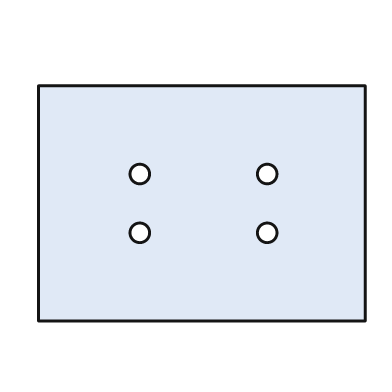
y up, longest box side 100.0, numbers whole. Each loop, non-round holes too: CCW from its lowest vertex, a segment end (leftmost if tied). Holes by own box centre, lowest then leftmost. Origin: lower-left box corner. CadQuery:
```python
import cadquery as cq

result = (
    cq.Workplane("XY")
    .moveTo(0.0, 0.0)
    .lineTo(100.0, 0.0)
    .lineTo(100.0, 72.0)
    .lineTo(0.0, 72.0)
    .close()
    .moveTo(31.0, 27.0)
    .circle(3.0)
    .moveTo(70.0, 27.0)
    .circle(3.0)
    .moveTo(31.0, 45.0)
    .circle(3.0)
    .moveTo(70.0, 45.0)
    .circle(3.0)
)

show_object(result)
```